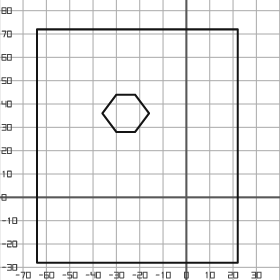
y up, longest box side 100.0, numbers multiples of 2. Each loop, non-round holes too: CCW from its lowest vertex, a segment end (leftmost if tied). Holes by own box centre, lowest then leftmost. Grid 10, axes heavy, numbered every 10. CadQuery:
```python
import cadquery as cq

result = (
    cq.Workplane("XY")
    .moveTo(-64.0, -28.0)
    .lineTo(22.0, -28.0)
    .lineTo(22.0, 72.0)
    .lineTo(-64.0, 72.0)
    .close()
    .moveTo(-30.0, 28.0)
    .lineTo(-22.0, 28.0)
    .lineTo(-16.0, 36.0)
    .lineTo(-22.0, 44.0)
    .lineTo(-30.0, 44.0)
    .lineTo(-36.0, 36.0)
    .close()
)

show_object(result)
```